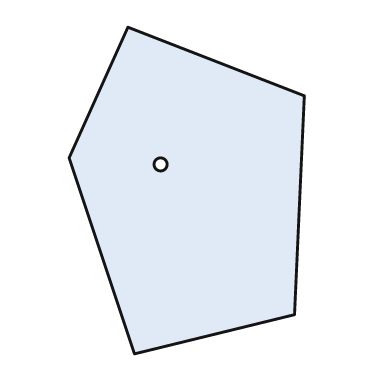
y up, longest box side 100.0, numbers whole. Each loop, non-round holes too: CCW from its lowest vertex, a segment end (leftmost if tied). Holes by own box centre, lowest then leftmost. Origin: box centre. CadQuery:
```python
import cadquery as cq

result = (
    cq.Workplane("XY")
    .moveTo(-16.0, -50.0)
    .lineTo(33.0, -38.0)
    .lineTo(36.0, 29.0)
    .lineTo(-18.0, 50.0)
    .lineTo(-36.0, 10.0)
    .close()
    .moveTo(-8.0, 8.0)
    .circle(2.0)
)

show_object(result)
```